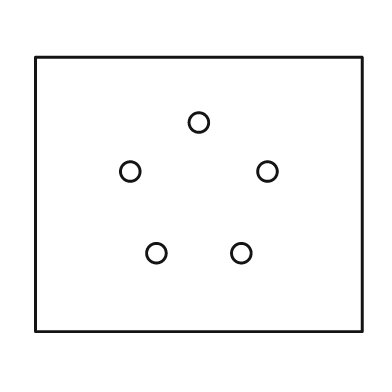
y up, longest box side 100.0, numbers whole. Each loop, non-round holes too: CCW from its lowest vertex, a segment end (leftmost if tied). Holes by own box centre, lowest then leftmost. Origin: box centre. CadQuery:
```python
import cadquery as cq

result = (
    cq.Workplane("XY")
    .moveTo(-50.0, -42.0)
    .lineTo(50.0, -42.0)
    .lineTo(50.0, 42.0)
    .lineTo(-50.0, 42.0)
    .close()
    .moveTo(-13.0, -18.0)
    .circle(3.0)
    .moveTo(13.0, -18.0)
    .circle(3.0)
    .moveTo(-21.0, 7.0)
    .circle(3.0)
    .moveTo(21.0, 7.0)
    .circle(3.0)
    .moveTo(0.0, 22.0)
    .circle(3.0)
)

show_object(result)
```